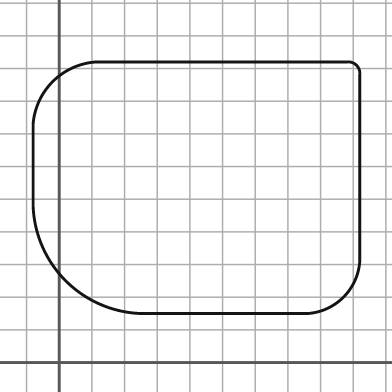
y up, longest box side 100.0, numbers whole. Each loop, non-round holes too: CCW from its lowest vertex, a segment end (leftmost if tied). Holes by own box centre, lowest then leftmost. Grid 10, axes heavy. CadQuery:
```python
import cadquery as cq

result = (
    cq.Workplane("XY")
    .moveTo(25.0, 15.0)
    .lineTo(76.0, 15.0)
    .threePointArc((87.0, 20.0), (92.0, 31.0))
    .lineTo(92.0, 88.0)
    .threePointArc((91.0, 91.0), (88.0, 92.0))
    .lineTo(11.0, 92.0)
    .threePointArc((-2.0, 86.0), (-8.0, 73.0))
    .lineTo(-8.0, 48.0)
    .threePointArc((2.0, 25.0), (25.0, 15.0))
    .close()
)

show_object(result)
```